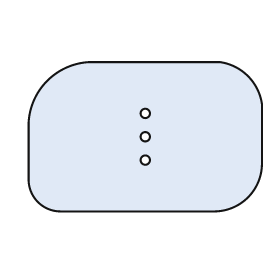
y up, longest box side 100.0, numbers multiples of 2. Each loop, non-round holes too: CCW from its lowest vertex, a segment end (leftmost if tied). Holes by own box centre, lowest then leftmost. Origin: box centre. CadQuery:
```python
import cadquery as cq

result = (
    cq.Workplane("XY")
    .moveTo(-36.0, -32.0)
    .lineTo(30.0, -32.0)
    .threePointArc((44.0, -26.0), (50.0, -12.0))
    .lineTo(50.0, 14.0)
    .threePointArc((44.0, 26.0), (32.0, 32.0))
    .lineTo(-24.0, 32.0)
    .threePointArc((-42.0, 24.0), (-50.0, 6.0))
    .lineTo(-50.0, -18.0)
    .threePointArc((-46.0, -28.0), (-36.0, -32.0))
    .close()
    .moveTo(0.0, -10.0)
    .circle(2.0)
    .moveTo(0.0, 0.0)
    .circle(2.0)
    .moveTo(0.0, 10.0)
    .circle(2.0)
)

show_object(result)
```